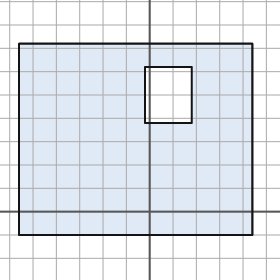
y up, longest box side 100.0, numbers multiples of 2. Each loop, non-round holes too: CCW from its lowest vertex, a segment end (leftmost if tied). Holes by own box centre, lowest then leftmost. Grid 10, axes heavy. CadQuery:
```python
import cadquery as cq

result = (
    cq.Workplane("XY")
    .moveTo(-56.0, -10.0)
    .lineTo(44.0, -10.0)
    .lineTo(44.0, 72.0)
    .lineTo(-56.0, 72.0)
    .close()
    .moveTo(-2.0, 38.0)
    .lineTo(18.0, 38.0)
    .lineTo(18.0, 62.0)
    .lineTo(-2.0, 62.0)
    .close()
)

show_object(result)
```